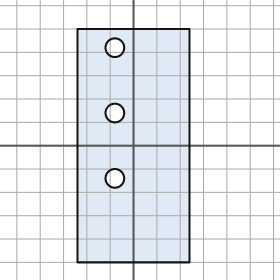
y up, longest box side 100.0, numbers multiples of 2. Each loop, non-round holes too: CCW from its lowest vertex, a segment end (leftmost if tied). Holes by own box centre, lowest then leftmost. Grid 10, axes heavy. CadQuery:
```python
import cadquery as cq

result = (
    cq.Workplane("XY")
    .moveTo(-24.0, -50.0)
    .lineTo(24.0, -50.0)
    .lineTo(24.0, 50.0)
    .lineTo(-24.0, 50.0)
    .close()
    .moveTo(-8.0, -14.0)
    .circle(4.0)
    .moveTo(-8.0, 14.0)
    .circle(4.0)
    .moveTo(-8.0, 42.0)
    .circle(4.0)
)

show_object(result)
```